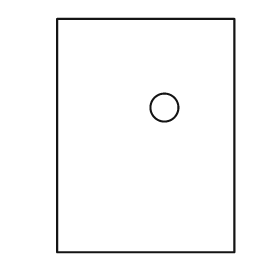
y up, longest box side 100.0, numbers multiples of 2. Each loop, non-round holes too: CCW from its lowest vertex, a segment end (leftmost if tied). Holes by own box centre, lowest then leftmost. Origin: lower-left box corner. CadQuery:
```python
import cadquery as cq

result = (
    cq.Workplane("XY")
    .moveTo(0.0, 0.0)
    .lineTo(76.0, 0.0)
    .lineTo(76.0, 100.0)
    .lineTo(0.0, 100.0)
    .close()
    .moveTo(46.0, 62.0)
    .circle(6.0)
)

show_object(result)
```